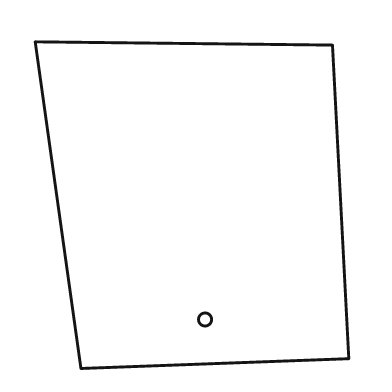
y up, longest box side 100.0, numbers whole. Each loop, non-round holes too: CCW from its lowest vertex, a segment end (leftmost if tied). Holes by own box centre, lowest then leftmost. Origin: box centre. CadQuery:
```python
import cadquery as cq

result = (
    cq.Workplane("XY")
    .moveTo(-34.0, -50.0)
    .lineTo(48.0, -47.0)
    .lineTo(43.0, 49.0)
    .lineTo(-48.0, 50.0)
    .close()
    .moveTo(4.0, -35.0)
    .circle(2.0)
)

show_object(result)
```